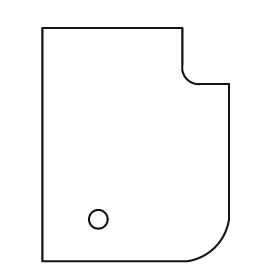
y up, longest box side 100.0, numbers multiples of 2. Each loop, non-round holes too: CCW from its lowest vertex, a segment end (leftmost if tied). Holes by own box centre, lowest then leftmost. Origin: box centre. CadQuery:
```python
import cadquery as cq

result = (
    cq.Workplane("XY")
    .moveTo(-40.0, -50.0)
    .lineTo(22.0, -50.0)
    .threePointArc((34.0, -44.0), (40.0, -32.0))
    .lineTo(40.0, 26.0)
    .lineTo(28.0, 26.0)
    .threePointArc((22.0, 28.0), (20.0, 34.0))
    .lineTo(20.0, 50.0)
    .lineTo(-40.0, 50.0)
    .close()
    .moveTo(-16.0, -32.0)
    .circle(4.0)
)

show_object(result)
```